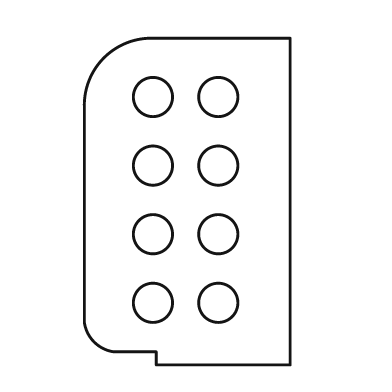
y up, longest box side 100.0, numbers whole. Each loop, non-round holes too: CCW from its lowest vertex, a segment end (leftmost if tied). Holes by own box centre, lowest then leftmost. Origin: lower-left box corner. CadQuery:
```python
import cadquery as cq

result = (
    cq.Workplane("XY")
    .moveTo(22.0, 0.0)
    .lineTo(63.0, 0.0)
    .lineTo(63.0, 100.0)
    .lineTo(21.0, 100.0)
    .threePointArc((6.0, 94.0), (0.0, 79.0))
    .lineTo(0.0, 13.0)
    .threePointArc((3.0, 7.0), (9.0, 4.0))
    .lineTo(22.0, 4.0)
    .close()
    .moveTo(21.0, 19.0)
    .circle(6.0)
    .moveTo(41.0, 19.0)
    .circle(6.0)
    .moveTo(21.0, 40.0)
    .circle(6.0)
    .moveTo(41.0, 40.0)
    .circle(6.0)
    .moveTo(21.0, 61.0)
    .circle(6.0)
    .moveTo(41.0, 61.0)
    .circle(6.0)
    .moveTo(21.0, 82.0)
    .circle(6.0)
    .moveTo(41.0, 82.0)
    .circle(6.0)
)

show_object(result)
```